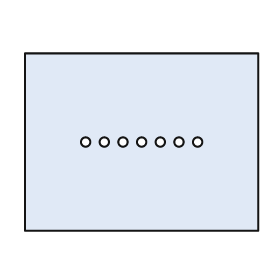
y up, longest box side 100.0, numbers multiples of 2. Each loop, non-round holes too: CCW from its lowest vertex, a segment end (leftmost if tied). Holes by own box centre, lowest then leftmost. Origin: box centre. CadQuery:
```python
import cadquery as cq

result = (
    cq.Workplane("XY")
    .moveTo(-50.0, -38.0)
    .lineTo(50.0, -38.0)
    .lineTo(50.0, 38.0)
    .lineTo(-50.0, 38.0)
    .close()
    .moveTo(-24.0, 0.0)
    .circle(2.0)
    .moveTo(-16.0, 0.0)
    .circle(2.0)
    .moveTo(-8.0, 0.0)
    .circle(2.0)
    .moveTo(0.0, 0.0)
    .circle(2.0)
    .moveTo(8.0, 0.0)
    .circle(2.0)
    .moveTo(16.0, 0.0)
    .circle(2.0)
    .moveTo(24.0, 0.0)
    .circle(2.0)
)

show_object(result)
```